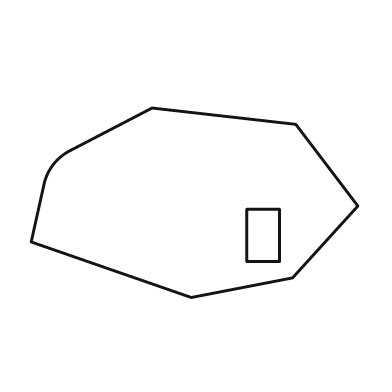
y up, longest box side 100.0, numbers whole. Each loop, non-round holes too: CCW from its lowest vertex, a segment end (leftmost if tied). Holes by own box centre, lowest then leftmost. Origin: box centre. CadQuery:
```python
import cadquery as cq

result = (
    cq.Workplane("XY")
    .moveTo(-1.0, -29.0)
    .lineTo(30.0, -23.0)
    .lineTo(50.0, -1.0)
    .lineTo(31.0, 24.0)
    .lineTo(-13.0, 29.0)
    .lineTo(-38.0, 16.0)
    .threePointArc((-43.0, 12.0), (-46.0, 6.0))
    .lineTo(-50.0, -12.0)
    .close()
    .moveTo(16.0, -18.0)
    .lineTo(26.0, -18.0)
    .lineTo(26.0, -2.0)
    .lineTo(16.0, -2.0)
    .close()
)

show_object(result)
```